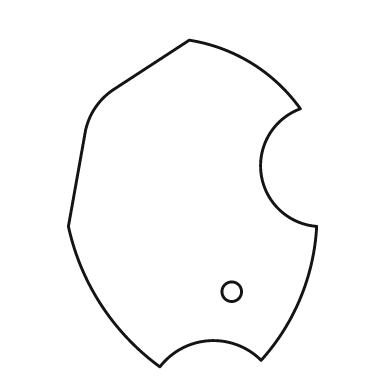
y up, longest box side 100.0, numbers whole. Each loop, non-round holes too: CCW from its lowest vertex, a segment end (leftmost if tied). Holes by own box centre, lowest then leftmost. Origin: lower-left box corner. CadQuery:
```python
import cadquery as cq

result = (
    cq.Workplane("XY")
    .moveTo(28.0, 0.0)
    .threePointArc((43.0, 8.0), (59.0, 2.0))
    .threePointArc((71.0, 21.0), (76.0, 43.0))
    .threePointArc((59.0, 59.0), (71.0, 79.0))
    .threePointArc((56.0, 93.0), (37.0, 100.0))
    .lineTo(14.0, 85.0)
    .threePointArc((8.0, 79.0), (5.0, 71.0))
    .lineTo(0.0, 43.0)
    .threePointArc((10.0, 19.0), (28.0, 0.0))
    .close()
    .moveTo(50.0, 23.0)
    .circle(3.0)
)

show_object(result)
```